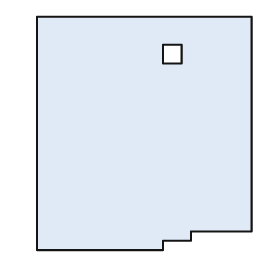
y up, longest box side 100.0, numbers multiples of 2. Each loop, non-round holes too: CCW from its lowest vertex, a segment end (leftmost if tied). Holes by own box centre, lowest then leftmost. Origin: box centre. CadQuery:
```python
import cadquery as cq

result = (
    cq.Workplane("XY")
    .moveTo(-46.0, -50.0)
    .lineTo(8.0, -50.0)
    .lineTo(8.0, -46.0)
    .lineTo(20.0, -46.0)
    .lineTo(20.0, -42.0)
    .lineTo(46.0, -42.0)
    .lineTo(46.0, 50.0)
    .lineTo(-46.0, 50.0)
    .close()
    .moveTo(8.0, 30.0)
    .lineTo(16.0, 30.0)
    .lineTo(16.0, 38.0)
    .lineTo(8.0, 38.0)
    .close()
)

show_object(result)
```